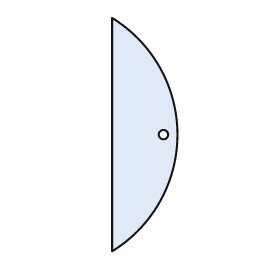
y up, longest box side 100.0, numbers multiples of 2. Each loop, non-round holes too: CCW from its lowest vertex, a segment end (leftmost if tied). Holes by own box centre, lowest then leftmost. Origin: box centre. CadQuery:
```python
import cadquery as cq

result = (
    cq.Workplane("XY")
    .moveTo(-14.0, -50.0)
    .threePointArc((14.0, 0.0), (-14.0, 50.0))
    .close()
    .moveTo(8.0, 0.0)
    .circle(2.0)
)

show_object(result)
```